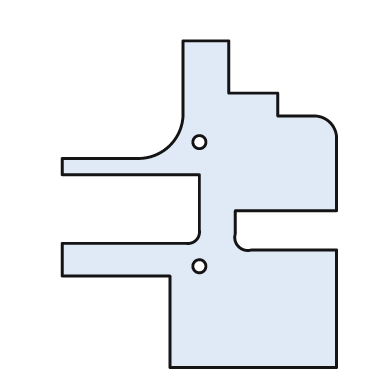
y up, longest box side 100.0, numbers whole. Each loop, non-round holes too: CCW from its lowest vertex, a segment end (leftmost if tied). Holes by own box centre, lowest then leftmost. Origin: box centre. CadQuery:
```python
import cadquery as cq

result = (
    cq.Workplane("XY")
    .moveTo(-9.0, -50.0)
    .lineTo(42.0, -50.0)
    .lineTo(42.0, -14.0)
    .lineTo(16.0, -14.0)
    .threePointArc((12.0, -13.0), (11.0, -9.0))
    .lineTo(11.0, -2.0)
    .lineTo(42.0, -2.0)
    .lineTo(42.0, 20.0)
    .threePointArc((40.0, 25.0), (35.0, 27.0))
    .lineTo(24.0, 27.0)
    .lineTo(24.0, 34.0)
    .lineTo(9.0, 34.0)
    .lineTo(9.0, 50.0)
    .lineTo(-5.0, 50.0)
    .lineTo(-5.0, 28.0)
    .threePointArc((-9.0, 18.0), (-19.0, 14.0))
    .lineTo(-42.0, 14.0)
    .lineTo(-42.0, 9.0)
    .lineTo(0.0, 9.0)
    .lineTo(0.0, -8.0)
    .threePointArc((-1.0, -11.0), (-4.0, -12.0))
    .lineTo(-42.0, -12.0)
    .lineTo(-42.0, -22.0)
    .lineTo(-9.0, -22.0)
    .close()
    .moveTo(0.0, -19.0)
    .circle(2.0)
    .moveTo(0.0, 19.0)
    .circle(2.0)
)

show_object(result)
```